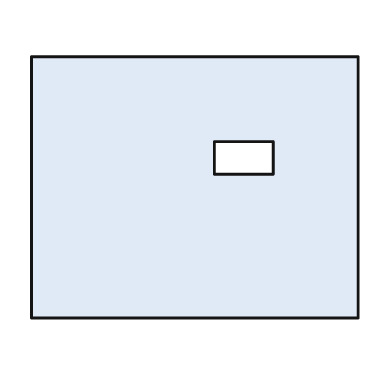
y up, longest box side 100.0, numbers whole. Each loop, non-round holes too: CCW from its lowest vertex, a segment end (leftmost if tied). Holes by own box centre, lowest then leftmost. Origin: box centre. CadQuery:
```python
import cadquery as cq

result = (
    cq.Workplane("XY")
    .moveTo(-50.0, -40.0)
    .lineTo(50.0, -40.0)
    .lineTo(50.0, 40.0)
    .lineTo(-50.0, 40.0)
    .close()
    .moveTo(6.0, 4.0)
    .lineTo(24.0, 4.0)
    .lineTo(24.0, 14.0)
    .lineTo(6.0, 14.0)
    .close()
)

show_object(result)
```